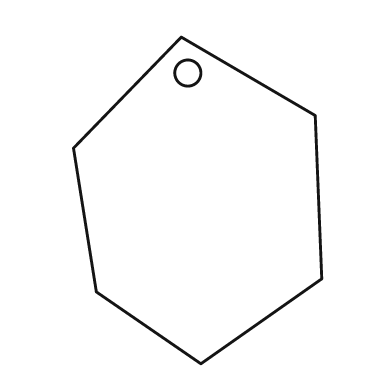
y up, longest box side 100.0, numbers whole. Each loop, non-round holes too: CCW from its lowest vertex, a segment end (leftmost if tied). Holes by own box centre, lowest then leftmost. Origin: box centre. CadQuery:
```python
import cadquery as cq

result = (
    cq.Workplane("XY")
    .moveTo(1.0, -50.0)
    .lineTo(38.0, -24.0)
    .lineTo(36.0, 26.0)
    .lineTo(-5.0, 50.0)
    .lineTo(-38.0, 16.0)
    .lineTo(-31.0, -28.0)
    .close()
    .moveTo(-3.0, 39.0)
    .circle(4.0)
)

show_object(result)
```